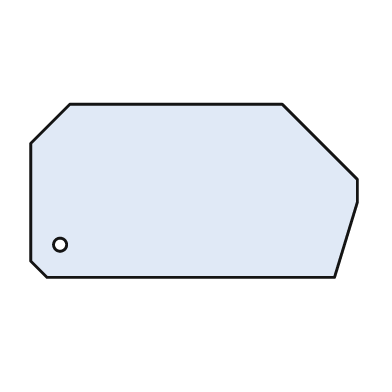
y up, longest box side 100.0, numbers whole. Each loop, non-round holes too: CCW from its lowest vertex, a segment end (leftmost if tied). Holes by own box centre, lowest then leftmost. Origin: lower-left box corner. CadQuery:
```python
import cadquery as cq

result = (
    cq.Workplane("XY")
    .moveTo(5.0, 0.0)
    .lineTo(93.0, 0.0)
    .lineTo(100.0, 23.0)
    .lineTo(100.0, 30.0)
    .lineTo(77.0, 53.0)
    .lineTo(12.0, 53.0)
    .lineTo(0.0, 41.0)
    .lineTo(0.0, 5.0)
    .close()
    .moveTo(9.0, 10.0)
    .circle(2.0)
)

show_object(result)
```